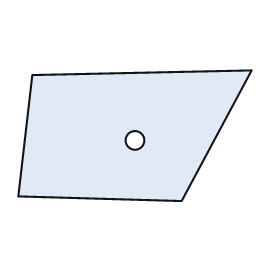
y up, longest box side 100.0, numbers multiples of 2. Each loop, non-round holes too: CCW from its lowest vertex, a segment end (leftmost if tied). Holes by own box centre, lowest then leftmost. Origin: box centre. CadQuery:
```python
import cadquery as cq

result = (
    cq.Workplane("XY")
    .moveTo(20.0, -28.0)
    .lineTo(50.0, 28.0)
    .lineTo(-44.0, 26.0)
    .lineTo(-50.0, -26.0)
    .close()
    .moveTo(0.0, -2.0)
    .circle(4.0)
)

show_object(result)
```